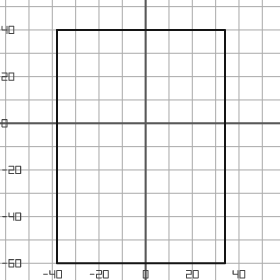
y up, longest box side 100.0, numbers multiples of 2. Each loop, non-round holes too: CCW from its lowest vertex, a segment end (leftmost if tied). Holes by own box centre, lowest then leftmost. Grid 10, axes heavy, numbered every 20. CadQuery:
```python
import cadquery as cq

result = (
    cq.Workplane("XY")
    .moveTo(-38.0, -60.0)
    .lineTo(34.0, -60.0)
    .lineTo(34.0, 40.0)
    .lineTo(-38.0, 40.0)
    .close()
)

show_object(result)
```